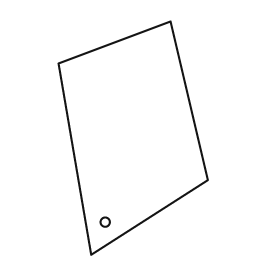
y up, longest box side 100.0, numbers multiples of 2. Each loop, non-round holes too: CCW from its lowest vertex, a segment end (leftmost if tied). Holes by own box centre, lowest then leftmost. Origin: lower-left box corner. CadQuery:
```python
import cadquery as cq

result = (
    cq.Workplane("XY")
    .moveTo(14.0, 0.0)
    .lineTo(64.0, 32.0)
    .lineTo(48.0, 100.0)
    .lineTo(0.0, 82.0)
    .close()
    .moveTo(20.0, 14.0)
    .circle(2.0)
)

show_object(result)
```